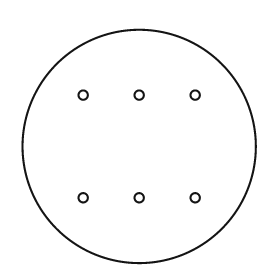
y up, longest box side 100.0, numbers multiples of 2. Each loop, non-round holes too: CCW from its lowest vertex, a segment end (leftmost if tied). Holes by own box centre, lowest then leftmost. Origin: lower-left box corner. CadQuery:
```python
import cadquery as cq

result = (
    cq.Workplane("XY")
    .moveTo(50.0, 50.0)
    .circle(50.0)
    .moveTo(26.0, 28.0)
    .circle(2.0)
    .moveTo(50.0, 28.0)
    .circle(2.0)
    .moveTo(74.0, 28.0)
    .circle(2.0)
    .moveTo(26.0, 72.0)
    .circle(2.0)
    .moveTo(50.0, 72.0)
    .circle(2.0)
    .moveTo(74.0, 72.0)
    .circle(2.0)
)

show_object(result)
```